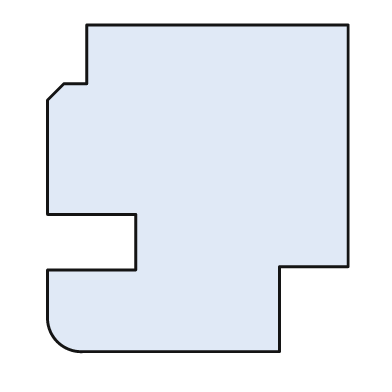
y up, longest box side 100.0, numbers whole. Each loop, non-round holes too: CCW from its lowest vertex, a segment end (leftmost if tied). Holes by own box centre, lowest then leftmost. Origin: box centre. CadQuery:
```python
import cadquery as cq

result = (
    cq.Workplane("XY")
    .moveTo(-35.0, -50.0)
    .lineTo(25.0, -50.0)
    .lineTo(25.0, -24.0)
    .lineTo(46.0, -24.0)
    .lineTo(46.0, 50.0)
    .lineTo(-34.0, 50.0)
    .lineTo(-34.0, 32.0)
    .lineTo(-41.0, 32.0)
    .lineTo(-46.0, 27.0)
    .lineTo(-46.0, -8.0)
    .lineTo(-19.0, -8.0)
    .lineTo(-19.0, -25.0)
    .lineTo(-46.0, -25.0)
    .lineTo(-46.0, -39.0)
    .threePointArc((-43.0, -47.0), (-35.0, -50.0))
    .close()
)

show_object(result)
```